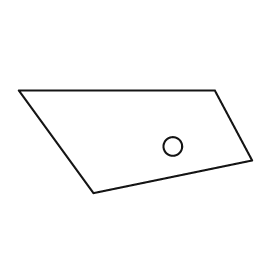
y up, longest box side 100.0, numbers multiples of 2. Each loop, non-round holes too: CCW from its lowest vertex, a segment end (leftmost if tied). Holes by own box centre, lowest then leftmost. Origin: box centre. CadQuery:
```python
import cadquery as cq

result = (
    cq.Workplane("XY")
    .moveTo(-18.0, -22.0)
    .lineTo(50.0, -8.0)
    .lineTo(34.0, 22.0)
    .lineTo(-50.0, 22.0)
    .close()
    .moveTo(16.0, -2.0)
    .circle(4.0)
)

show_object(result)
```